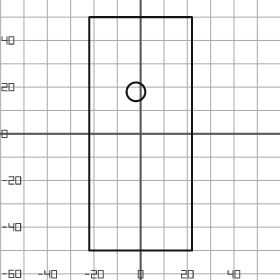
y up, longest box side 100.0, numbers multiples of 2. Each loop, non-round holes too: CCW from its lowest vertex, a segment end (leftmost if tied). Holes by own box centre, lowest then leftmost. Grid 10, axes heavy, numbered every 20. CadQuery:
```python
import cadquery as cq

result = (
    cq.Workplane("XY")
    .moveTo(-22.0, -50.0)
    .lineTo(22.0, -50.0)
    .lineTo(22.0, 50.0)
    .lineTo(-22.0, 50.0)
    .close()
    .moveTo(-2.0, 18.0)
    .circle(4.0)
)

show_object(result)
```